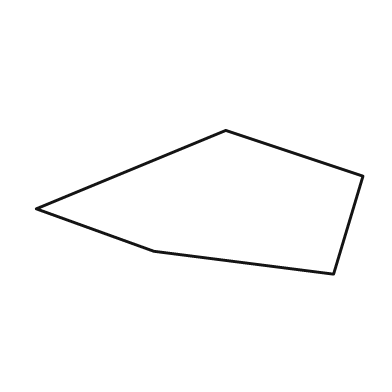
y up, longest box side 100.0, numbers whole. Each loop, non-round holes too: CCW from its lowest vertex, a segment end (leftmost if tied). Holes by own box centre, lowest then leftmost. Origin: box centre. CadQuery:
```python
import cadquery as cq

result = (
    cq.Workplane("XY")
    .moveTo(41.0, -22.0)
    .lineTo(50.0, 8.0)
    .lineTo(8.0, 22.0)
    .lineTo(-50.0, -2.0)
    .lineTo(-14.0, -15.0)
    .close()
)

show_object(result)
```